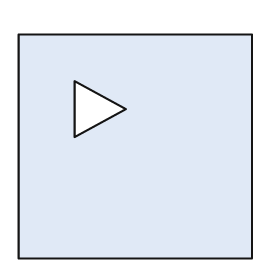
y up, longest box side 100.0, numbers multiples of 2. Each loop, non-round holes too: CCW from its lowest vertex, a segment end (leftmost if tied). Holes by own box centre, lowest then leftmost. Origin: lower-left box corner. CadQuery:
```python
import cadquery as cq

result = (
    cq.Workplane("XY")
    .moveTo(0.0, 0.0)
    .lineTo(100.0, 0.0)
    .lineTo(100.0, 96.0)
    .lineTo(0.0, 96.0)
    .close()
    .moveTo(24.0, 52.0)
    .lineTo(46.0, 64.0)
    .lineTo(24.0, 76.0)
    .close()
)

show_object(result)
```